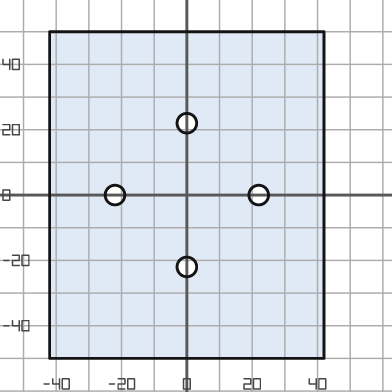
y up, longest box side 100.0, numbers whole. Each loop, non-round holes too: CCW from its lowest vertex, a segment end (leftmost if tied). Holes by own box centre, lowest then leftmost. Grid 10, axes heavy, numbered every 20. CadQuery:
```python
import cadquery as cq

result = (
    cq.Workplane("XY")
    .moveTo(-42.0, -50.0)
    .lineTo(42.0, -50.0)
    .lineTo(42.0, 50.0)
    .lineTo(-42.0, 50.0)
    .close()
    .moveTo(0.0, -22.0)
    .circle(3.0)
    .moveTo(-22.0, 0.0)
    .circle(3.0)
    .moveTo(22.0, 0.0)
    .circle(3.0)
    .moveTo(0.0, 22.0)
    .circle(3.0)
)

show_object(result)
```